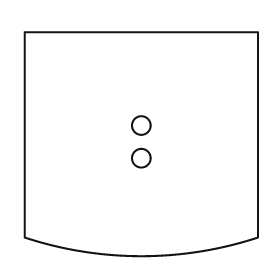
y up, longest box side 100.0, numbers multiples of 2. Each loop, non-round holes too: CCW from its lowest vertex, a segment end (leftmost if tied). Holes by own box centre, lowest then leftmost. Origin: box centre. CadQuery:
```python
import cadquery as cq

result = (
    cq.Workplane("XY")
    .moveTo(-50.0, -40.0)
    .threePointArc((0.0, -48.0), (50.0, -40.0))
    .lineTo(50.0, 48.0)
    .lineTo(-50.0, 48.0)
    .close()
    .moveTo(0.0, -6.0)
    .circle(4.0)
    .moveTo(0.0, 8.0)
    .circle(4.0)
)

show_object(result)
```